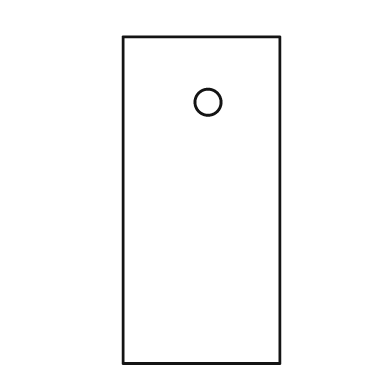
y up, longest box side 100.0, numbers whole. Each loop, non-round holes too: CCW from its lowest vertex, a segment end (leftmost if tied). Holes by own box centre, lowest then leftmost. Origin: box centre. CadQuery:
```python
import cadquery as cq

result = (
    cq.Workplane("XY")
    .moveTo(-24.0, -50.0)
    .lineTo(24.0, -50.0)
    .lineTo(24.0, 50.0)
    .lineTo(-24.0, 50.0)
    .close()
    .moveTo(2.0, 30.0)
    .circle(4.0)
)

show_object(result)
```